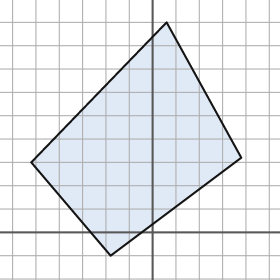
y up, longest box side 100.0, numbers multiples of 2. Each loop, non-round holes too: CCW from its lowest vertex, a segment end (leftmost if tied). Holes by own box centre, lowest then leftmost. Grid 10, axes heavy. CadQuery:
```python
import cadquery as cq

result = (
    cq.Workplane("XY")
    .moveTo(-18.0, -10.0)
    .lineTo(38.0, 32.0)
    .lineTo(6.0, 90.0)
    .lineTo(-52.0, 30.0)
    .close()
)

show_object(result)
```